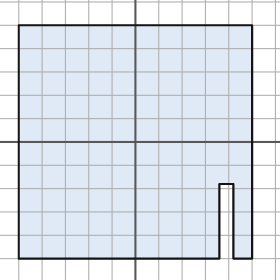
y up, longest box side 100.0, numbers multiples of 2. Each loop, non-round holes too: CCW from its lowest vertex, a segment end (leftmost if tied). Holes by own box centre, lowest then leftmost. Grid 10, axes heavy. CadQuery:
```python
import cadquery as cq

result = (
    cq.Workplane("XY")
    .moveTo(-50.0, -50.0)
    .lineTo(36.0, -50.0)
    .lineTo(36.0, -18.0)
    .lineTo(42.0, -18.0)
    .lineTo(42.0, -50.0)
    .lineTo(50.0, -50.0)
    .lineTo(50.0, 50.0)
    .lineTo(-50.0, 50.0)
    .close()
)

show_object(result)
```